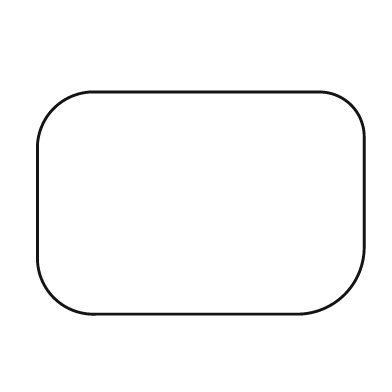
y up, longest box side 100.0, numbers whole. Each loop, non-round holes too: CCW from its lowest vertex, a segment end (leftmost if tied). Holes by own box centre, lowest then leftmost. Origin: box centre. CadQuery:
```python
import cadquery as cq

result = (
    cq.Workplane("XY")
    .moveTo(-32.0, -34.0)
    .lineTo(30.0, -34.0)
    .threePointArc((44.0, -28.0), (50.0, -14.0))
    .lineTo(50.0, 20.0)
    .threePointArc((46.0, 30.0), (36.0, 34.0))
    .lineTo(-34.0, 34.0)
    .threePointArc((-45.0, 29.0), (-50.0, 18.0))
    .lineTo(-50.0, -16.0)
    .threePointArc((-45.0, -29.0), (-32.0, -34.0))
    .close()
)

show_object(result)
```